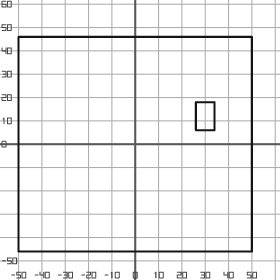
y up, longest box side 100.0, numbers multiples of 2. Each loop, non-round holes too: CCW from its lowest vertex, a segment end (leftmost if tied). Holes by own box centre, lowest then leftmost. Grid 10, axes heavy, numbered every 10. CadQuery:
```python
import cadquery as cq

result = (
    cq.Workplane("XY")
    .moveTo(-50.0, -46.0)
    .lineTo(50.0, -46.0)
    .lineTo(50.0, 46.0)
    .lineTo(-50.0, 46.0)
    .close()
    .moveTo(26.0, 6.0)
    .lineTo(34.0, 6.0)
    .lineTo(34.0, 18.0)
    .lineTo(26.0, 18.0)
    .close()
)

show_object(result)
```